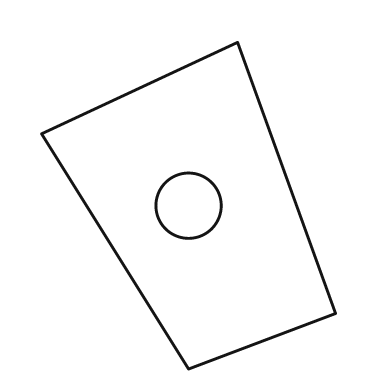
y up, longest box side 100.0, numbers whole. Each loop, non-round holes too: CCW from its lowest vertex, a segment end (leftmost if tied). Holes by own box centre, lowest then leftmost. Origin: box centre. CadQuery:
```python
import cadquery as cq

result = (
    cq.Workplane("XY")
    .moveTo(0.0, -50.0)
    .lineTo(45.0, -33.0)
    .lineTo(15.0, 50.0)
    .lineTo(-45.0, 22.0)
    .close()
    .moveTo(0.0, 0.0)
    .circle(10.0)
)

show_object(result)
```